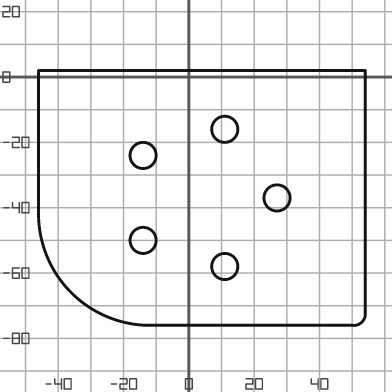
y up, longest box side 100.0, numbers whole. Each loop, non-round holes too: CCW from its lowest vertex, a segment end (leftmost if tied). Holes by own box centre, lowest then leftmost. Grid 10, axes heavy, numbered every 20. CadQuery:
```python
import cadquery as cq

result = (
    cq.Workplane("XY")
    .moveTo(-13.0, -76.0)
    .lineTo(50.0, -76.0)
    .threePointArc((53.0, -75.0), (54.0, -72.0))
    .lineTo(54.0, 2.0)
    .lineTo(-46.0, 2.0)
    .lineTo(-46.0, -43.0)
    .threePointArc((-36.0, -66.0), (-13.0, -76.0))
    .close()
    .moveTo(11.0, -58.0)
    .circle(4.0)
    .moveTo(-14.0, -50.0)
    .circle(4.0)
    .moveTo(27.0, -37.0)
    .circle(4.0)
    .moveTo(-14.0, -24.0)
    .circle(4.0)
    .moveTo(11.0, -16.0)
    .circle(4.0)
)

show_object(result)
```